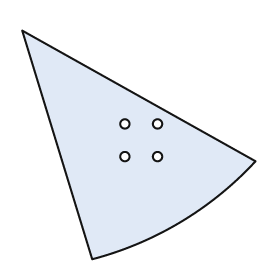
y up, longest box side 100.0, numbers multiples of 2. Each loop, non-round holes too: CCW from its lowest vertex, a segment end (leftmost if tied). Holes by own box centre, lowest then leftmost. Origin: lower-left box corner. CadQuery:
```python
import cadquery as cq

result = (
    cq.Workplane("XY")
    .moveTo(30.0, 0.0)
    .threePointArc((68.0, 16.0), (100.0, 42.0))
    .lineTo(0.0, 98.0)
    .close()
    .moveTo(44.0, 44.0)
    .circle(2.0)
    .moveTo(58.0, 44.0)
    .circle(2.0)
    .moveTo(44.0, 58.0)
    .circle(2.0)
    .moveTo(58.0, 58.0)
    .circle(2.0)
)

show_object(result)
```